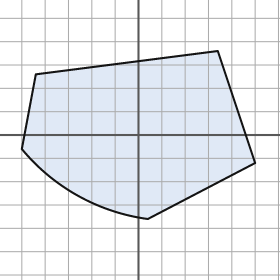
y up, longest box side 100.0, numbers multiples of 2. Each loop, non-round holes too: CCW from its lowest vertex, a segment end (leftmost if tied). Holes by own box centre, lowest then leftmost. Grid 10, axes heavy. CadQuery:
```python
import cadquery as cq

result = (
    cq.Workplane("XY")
    .moveTo(4.0, -36.0)
    .lineTo(50.0, -12.0)
    .lineTo(34.0, 36.0)
    .lineTo(-44.0, 26.0)
    .lineTo(-50.0, -6.0)
    .threePointArc((-26.0, -26.0), (4.0, -36.0))
    .close()
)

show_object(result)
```